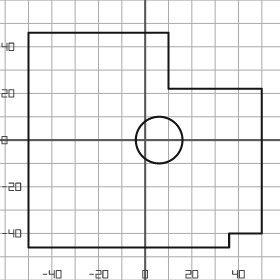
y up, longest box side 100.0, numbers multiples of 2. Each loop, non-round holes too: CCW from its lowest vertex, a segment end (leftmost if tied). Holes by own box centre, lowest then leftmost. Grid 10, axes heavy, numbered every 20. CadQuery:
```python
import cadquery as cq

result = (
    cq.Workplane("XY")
    .moveTo(-50.0, -46.0)
    .lineTo(36.0, -46.0)
    .lineTo(36.0, -40.0)
    .lineTo(50.0, -40.0)
    .lineTo(50.0, 22.0)
    .lineTo(10.0, 22.0)
    .lineTo(10.0, 46.0)
    .lineTo(-50.0, 46.0)
    .close()
    .moveTo(6.0, 0.0)
    .circle(10.0)
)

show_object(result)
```